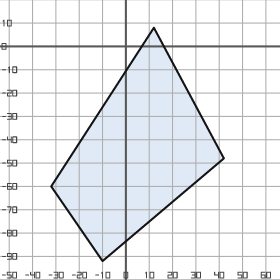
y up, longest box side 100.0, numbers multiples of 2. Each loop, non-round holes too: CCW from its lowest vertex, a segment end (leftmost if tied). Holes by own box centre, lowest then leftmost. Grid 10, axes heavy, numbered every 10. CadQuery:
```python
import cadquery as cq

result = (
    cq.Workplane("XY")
    .moveTo(-10.0, -92.0)
    .lineTo(42.0, -48.0)
    .lineTo(12.0, 8.0)
    .lineTo(-32.0, -60.0)
    .close()
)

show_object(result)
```